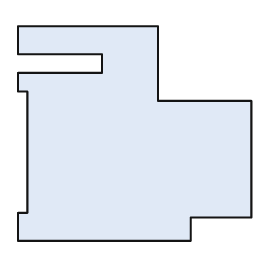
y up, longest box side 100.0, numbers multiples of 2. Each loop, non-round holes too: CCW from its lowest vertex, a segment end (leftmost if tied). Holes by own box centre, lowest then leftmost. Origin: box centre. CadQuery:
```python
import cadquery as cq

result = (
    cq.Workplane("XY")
    .moveTo(-50.0, -46.0)
    .lineTo(24.0, -46.0)
    .lineTo(24.0, -36.0)
    .lineTo(50.0, -36.0)
    .lineTo(50.0, 14.0)
    .lineTo(10.0, 14.0)
    .lineTo(10.0, 46.0)
    .lineTo(-50.0, 46.0)
    .lineTo(-50.0, 34.0)
    .lineTo(-14.0, 34.0)
    .lineTo(-14.0, 26.0)
    .lineTo(-50.0, 26.0)
    .lineTo(-50.0, 18.0)
    .lineTo(-46.0, 18.0)
    .lineTo(-46.0, -34.0)
    .lineTo(-50.0, -34.0)
    .close()
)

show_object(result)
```